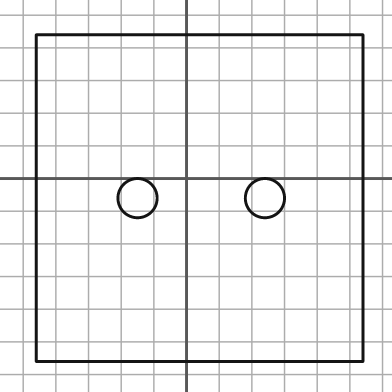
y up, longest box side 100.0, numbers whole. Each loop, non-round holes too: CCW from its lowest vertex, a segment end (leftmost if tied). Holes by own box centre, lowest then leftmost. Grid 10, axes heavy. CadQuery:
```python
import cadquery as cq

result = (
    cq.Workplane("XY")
    .moveTo(-46.0, -56.0)
    .lineTo(54.0, -56.0)
    .lineTo(54.0, 44.0)
    .lineTo(-46.0, 44.0)
    .close()
    .moveTo(-15.0, -6.0)
    .circle(6.0)
    .moveTo(24.0, -6.0)
    .circle(6.0)
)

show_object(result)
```